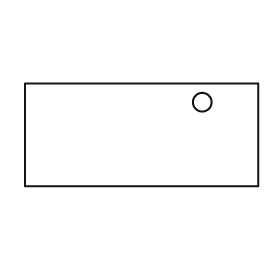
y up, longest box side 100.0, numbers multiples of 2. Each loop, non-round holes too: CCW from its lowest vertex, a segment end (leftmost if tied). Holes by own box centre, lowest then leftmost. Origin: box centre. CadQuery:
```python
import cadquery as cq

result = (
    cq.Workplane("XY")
    .moveTo(-50.0, -22.0)
    .lineTo(50.0, -22.0)
    .lineTo(50.0, 22.0)
    .lineTo(-50.0, 22.0)
    .close()
    .moveTo(26.0, 14.0)
    .circle(4.0)
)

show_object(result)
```